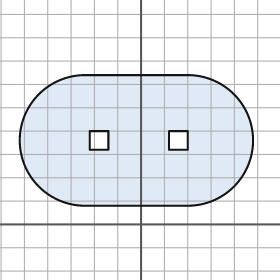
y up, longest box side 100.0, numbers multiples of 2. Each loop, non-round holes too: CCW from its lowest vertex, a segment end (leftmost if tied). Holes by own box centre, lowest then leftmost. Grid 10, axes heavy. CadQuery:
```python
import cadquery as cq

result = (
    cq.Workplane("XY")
    .moveTo(-24.0, 8.0)
    .lineTo(20.0, 8.0)
    .threePointArc((48.0, 36.0), (20.0, 64.0))
    .lineTo(-24.0, 64.0)
    .threePointArc((-52.0, 36.0), (-24.0, 8.0))
    .close()
    .moveTo(-22.0, 32.0)
    .lineTo(-14.0, 32.0)
    .lineTo(-14.0, 40.0)
    .lineTo(-22.0, 40.0)
    .close()
    .moveTo(12.0, 32.0)
    .lineTo(20.0, 32.0)
    .lineTo(20.0, 40.0)
    .lineTo(12.0, 40.0)
    .close()
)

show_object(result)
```